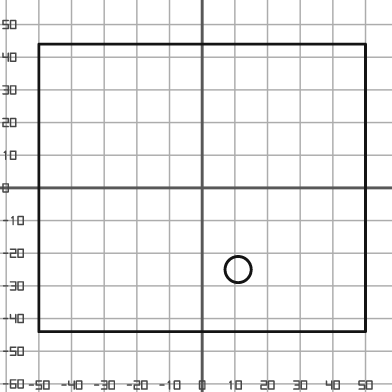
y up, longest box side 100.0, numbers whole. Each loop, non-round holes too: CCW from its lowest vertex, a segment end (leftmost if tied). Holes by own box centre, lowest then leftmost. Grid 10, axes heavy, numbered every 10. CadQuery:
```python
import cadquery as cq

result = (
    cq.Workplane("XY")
    .moveTo(-50.0, -44.0)
    .lineTo(50.0, -44.0)
    .lineTo(50.0, 44.0)
    .lineTo(-50.0, 44.0)
    .close()
    .moveTo(11.0, -25.0)
    .circle(4.0)
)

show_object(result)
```